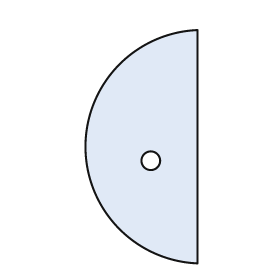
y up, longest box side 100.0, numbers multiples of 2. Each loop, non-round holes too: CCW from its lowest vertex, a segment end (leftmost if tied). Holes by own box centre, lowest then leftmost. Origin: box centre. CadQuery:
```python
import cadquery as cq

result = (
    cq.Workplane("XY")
    .moveTo(24.0, -50.0)
    .lineTo(24.0, 50.0)
    .threePointArc((-24.0, 0.0), (24.0, -50.0))
    .close()
    .moveTo(4.0, -6.0)
    .circle(4.0)
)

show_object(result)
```